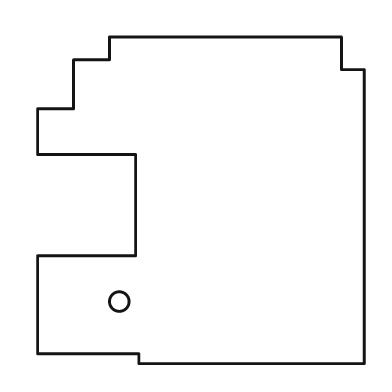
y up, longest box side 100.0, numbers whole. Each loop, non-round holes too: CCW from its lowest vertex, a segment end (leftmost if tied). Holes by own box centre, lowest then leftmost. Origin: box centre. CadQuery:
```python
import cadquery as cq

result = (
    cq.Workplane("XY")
    .moveTo(-19.0, -50.0)
    .lineTo(50.0, -50.0)
    .lineTo(50.0, 40.0)
    .lineTo(43.0, 40.0)
    .lineTo(43.0, 50.0)
    .lineTo(-28.0, 50.0)
    .lineTo(-28.0, 43.0)
    .lineTo(-39.0, 43.0)
    .lineTo(-39.0, 28.0)
    .lineTo(-50.0, 28.0)
    .lineTo(-50.0, 14.0)
    .lineTo(-20.0, 14.0)
    .lineTo(-20.0, -17.0)
    .lineTo(-50.0, -17.0)
    .lineTo(-50.0, -47.0)
    .lineTo(-19.0, -47.0)
    .close()
    .moveTo(-25.0, -31.0)
    .circle(3.0)
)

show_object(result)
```